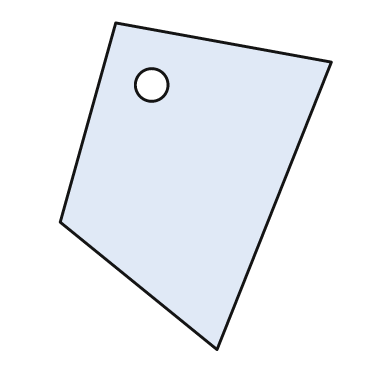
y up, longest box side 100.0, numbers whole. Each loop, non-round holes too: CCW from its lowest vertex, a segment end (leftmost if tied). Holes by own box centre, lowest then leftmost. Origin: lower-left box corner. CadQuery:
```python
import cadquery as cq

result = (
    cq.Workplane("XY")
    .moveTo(48.0, 0.0)
    .lineTo(83.0, 88.0)
    .lineTo(17.0, 100.0)
    .lineTo(0.0, 39.0)
    .close()
    .moveTo(28.0, 81.0)
    .circle(5.0)
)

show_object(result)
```